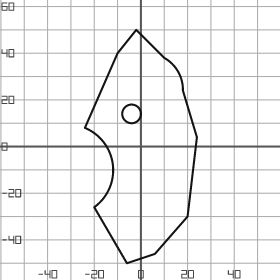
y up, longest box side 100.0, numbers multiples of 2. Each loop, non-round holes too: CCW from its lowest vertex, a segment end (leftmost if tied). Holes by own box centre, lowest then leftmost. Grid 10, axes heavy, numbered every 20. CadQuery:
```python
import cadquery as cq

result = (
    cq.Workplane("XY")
    .moveTo(-6.0, -50.0)
    .lineTo(6.0, -46.0)
    .lineTo(20.0, -30.0)
    .lineTo(24.0, 4.0)
    .lineTo(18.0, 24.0)
    .threePointArc((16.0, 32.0), (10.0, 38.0))
    .lineTo(-2.0, 50.0)
    .lineTo(-10.0, 40.0)
    .lineTo(-24.0, 8.0)
    .threePointArc((-12.0, -8.0), (-20.0, -26.0))
    .close()
    .moveTo(-4.0, 14.0)
    .circle(4.0)
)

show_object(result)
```